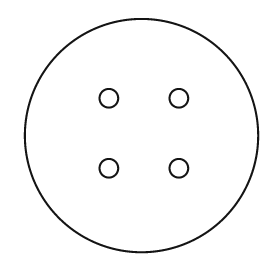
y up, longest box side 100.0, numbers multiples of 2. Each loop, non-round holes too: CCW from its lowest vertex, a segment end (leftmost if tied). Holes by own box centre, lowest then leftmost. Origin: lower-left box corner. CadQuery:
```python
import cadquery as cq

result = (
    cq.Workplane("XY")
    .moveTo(50.0, 50.0)
    .circle(50.0)
    .moveTo(36.0, 36.0)
    .circle(4.0)
    .moveTo(66.0, 36.0)
    .circle(4.0)
    .moveTo(36.0, 66.0)
    .circle(4.0)
    .moveTo(66.0, 66.0)
    .circle(4.0)
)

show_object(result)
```